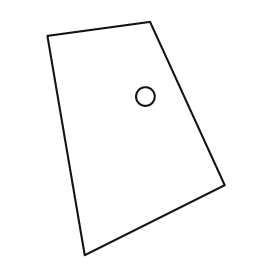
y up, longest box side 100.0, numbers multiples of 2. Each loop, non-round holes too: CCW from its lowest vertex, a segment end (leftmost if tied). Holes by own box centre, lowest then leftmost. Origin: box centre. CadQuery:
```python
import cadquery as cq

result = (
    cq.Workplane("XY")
    .moveTo(-22.0, -50.0)
    .lineTo(38.0, -20.0)
    .lineTo(6.0, 50.0)
    .lineTo(-38.0, 44.0)
    .close()
    .moveTo(4.0, 18.0)
    .circle(4.0)
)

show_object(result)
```